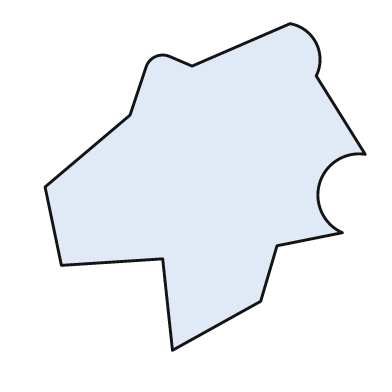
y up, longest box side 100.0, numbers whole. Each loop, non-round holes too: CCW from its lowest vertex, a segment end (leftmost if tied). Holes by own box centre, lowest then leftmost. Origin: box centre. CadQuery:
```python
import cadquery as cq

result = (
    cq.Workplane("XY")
    .moveTo(-10.0, -50.0)
    .lineTo(17.0, -35.0)
    .lineTo(22.0, -18.0)
    .lineTo(42.0, -14.0)
    .threePointArc((35.0, 1.0), (49.0, 10.0))
    .lineTo(34.0, 34.0)
    .threePointArc((34.0, 44.0), (26.0, 50.0))
    .lineTo(-4.0, 37.0)
    .lineTo(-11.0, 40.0)
    .threePointArc((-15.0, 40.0), (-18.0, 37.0))
    .lineTo(-23.0, 22.0)
    .lineTo(-49.0, 0.0)
    .lineTo(-44.0, -24.0)
    .lineTo(-13.0, -22.0)
    .close()
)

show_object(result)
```